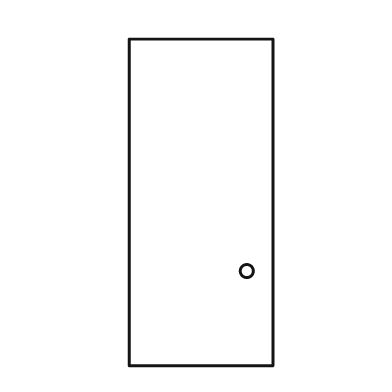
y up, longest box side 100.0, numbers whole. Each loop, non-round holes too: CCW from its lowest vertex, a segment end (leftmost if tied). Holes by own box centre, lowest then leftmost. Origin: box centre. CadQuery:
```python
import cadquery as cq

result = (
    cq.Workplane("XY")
    .moveTo(-22.0, -50.0)
    .lineTo(22.0, -50.0)
    .lineTo(22.0, 50.0)
    .lineTo(-22.0, 50.0)
    .close()
    .moveTo(14.0, -21.0)
    .circle(2.0)
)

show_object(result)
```